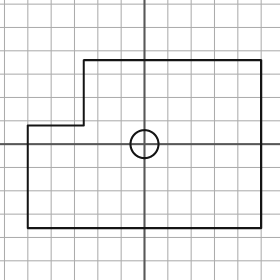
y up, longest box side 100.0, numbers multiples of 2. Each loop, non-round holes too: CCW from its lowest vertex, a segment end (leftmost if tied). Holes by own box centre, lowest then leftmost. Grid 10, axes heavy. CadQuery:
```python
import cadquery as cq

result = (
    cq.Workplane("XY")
    .moveTo(-50.0, -36.0)
    .lineTo(50.0, -36.0)
    .lineTo(50.0, 36.0)
    .lineTo(-26.0, 36.0)
    .lineTo(-26.0, 8.0)
    .lineTo(-50.0, 8.0)
    .close()
    .moveTo(0.0, 0.0)
    .circle(6.0)
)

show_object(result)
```